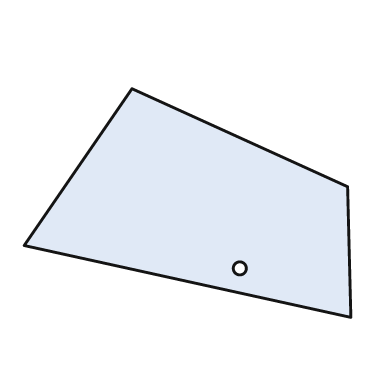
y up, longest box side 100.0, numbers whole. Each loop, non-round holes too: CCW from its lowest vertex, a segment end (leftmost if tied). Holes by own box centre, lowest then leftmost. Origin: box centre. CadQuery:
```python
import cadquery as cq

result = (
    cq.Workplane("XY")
    .moveTo(50.0, -35.0)
    .lineTo(49.0, 5.0)
    .lineTo(-17.0, 35.0)
    .lineTo(-50.0, -13.0)
    .close()
    .moveTo(16.0, -20.0)
    .circle(2.0)
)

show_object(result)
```